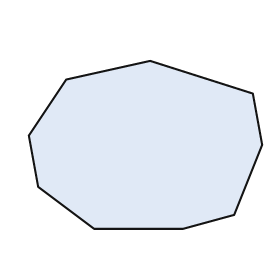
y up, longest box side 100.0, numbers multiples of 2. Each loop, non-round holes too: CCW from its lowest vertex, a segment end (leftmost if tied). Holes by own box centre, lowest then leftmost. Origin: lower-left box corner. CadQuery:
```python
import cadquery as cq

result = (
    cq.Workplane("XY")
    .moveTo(28.0, 0.0)
    .lineTo(66.0, 0.0)
    .lineTo(88.0, 6.0)
    .lineTo(100.0, 36.0)
    .lineTo(96.0, 58.0)
    .lineTo(52.0, 72.0)
    .lineTo(16.0, 64.0)
    .lineTo(0.0, 40.0)
    .lineTo(4.0, 18.0)
    .close()
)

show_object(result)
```